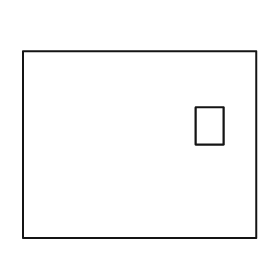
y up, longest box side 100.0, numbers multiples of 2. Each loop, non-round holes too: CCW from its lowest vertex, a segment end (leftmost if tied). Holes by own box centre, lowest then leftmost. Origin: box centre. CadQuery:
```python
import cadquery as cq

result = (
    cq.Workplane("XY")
    .moveTo(-50.0, -40.0)
    .lineTo(50.0, -40.0)
    .lineTo(50.0, 40.0)
    .lineTo(-50.0, 40.0)
    .close()
    .moveTo(24.0, 0.0)
    .lineTo(36.0, 0.0)
    .lineTo(36.0, 16.0)
    .lineTo(24.0, 16.0)
    .close()
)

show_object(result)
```